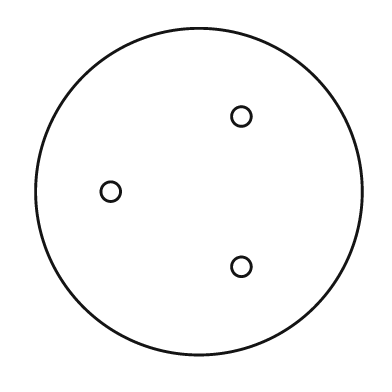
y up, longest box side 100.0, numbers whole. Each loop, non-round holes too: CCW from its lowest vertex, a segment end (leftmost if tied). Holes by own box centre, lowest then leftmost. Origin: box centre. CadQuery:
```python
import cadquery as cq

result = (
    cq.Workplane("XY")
    .moveTo(0.0, 0.0)
    .circle(50.0)
    .moveTo(13.0, -23.0)
    .circle(3.0)
    .moveTo(-27.0, 0.0)
    .circle(3.0)
    .moveTo(13.0, 23.0)
    .circle(3.0)
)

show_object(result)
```